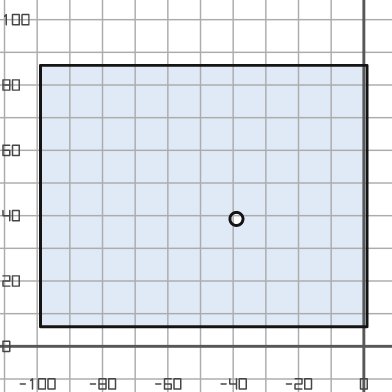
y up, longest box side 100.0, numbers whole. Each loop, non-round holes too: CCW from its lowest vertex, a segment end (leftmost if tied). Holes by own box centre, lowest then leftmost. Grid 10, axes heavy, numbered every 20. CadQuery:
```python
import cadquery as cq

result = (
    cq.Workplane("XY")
    .moveTo(-99.0, 6.0)
    .lineTo(1.0, 6.0)
    .lineTo(1.0, 86.0)
    .lineTo(-99.0, 86.0)
    .close()
    .moveTo(-39.0, 39.0)
    .circle(2.0)
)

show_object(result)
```